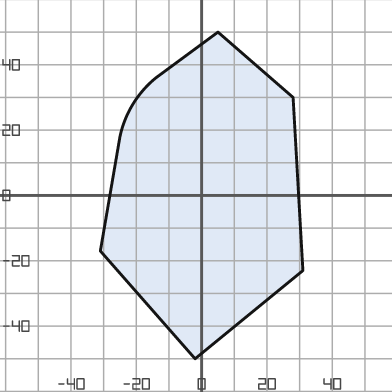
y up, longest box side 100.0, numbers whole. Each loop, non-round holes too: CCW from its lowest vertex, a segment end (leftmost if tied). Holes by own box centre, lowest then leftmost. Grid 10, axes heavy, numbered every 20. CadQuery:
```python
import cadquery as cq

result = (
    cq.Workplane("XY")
    .moveTo(-2.0, -50.0)
    .lineTo(31.0, -23.0)
    .lineTo(28.0, 30.0)
    .lineTo(5.0, 50.0)
    .lineTo(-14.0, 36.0)
    .threePointArc((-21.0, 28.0), (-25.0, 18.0))
    .lineTo(-31.0, -17.0)
    .close()
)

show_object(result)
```